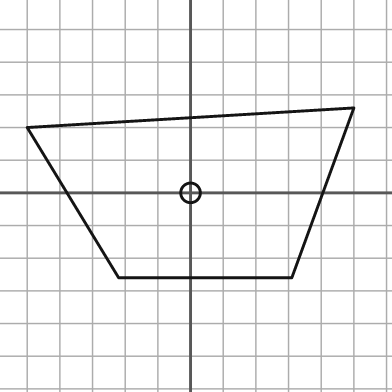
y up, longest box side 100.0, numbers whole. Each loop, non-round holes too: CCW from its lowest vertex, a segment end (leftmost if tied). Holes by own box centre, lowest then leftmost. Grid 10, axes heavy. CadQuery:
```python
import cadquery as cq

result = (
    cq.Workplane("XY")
    .moveTo(-22.0, -26.0)
    .lineTo(31.0, -26.0)
    .lineTo(50.0, 26.0)
    .lineTo(-50.0, 20.0)
    .close()
    .moveTo(0.0, 0.0)
    .circle(3.0)
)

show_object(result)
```